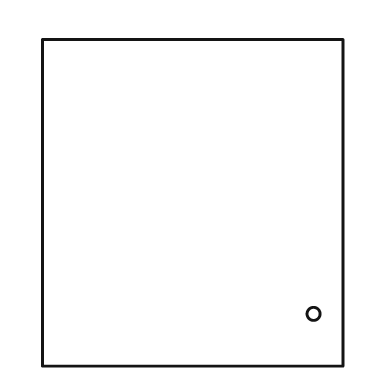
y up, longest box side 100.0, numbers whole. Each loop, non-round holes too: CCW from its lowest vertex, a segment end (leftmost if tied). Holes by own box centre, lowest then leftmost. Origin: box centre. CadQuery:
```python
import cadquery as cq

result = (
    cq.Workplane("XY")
    .moveTo(-46.0, -50.0)
    .lineTo(46.0, -50.0)
    .lineTo(46.0, 50.0)
    .lineTo(-46.0, 50.0)
    .close()
    .moveTo(37.0, -34.0)
    .circle(2.0)
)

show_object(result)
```